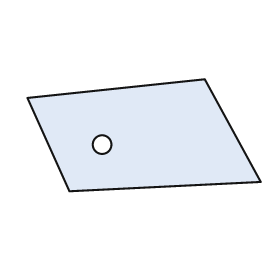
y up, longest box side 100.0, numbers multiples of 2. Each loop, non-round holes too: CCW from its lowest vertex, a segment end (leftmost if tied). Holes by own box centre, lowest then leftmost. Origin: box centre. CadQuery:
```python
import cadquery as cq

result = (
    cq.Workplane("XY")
    .moveTo(-32.0, -24.0)
    .lineTo(50.0, -20.0)
    .lineTo(26.0, 24.0)
    .lineTo(-50.0, 16.0)
    .close()
    .moveTo(-18.0, -4.0)
    .circle(4.0)
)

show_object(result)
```